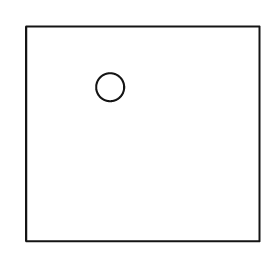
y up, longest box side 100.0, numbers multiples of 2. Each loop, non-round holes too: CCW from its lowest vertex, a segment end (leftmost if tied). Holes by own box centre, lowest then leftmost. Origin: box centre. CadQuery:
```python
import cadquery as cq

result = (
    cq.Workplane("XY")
    .moveTo(-50.0, -46.0)
    .lineTo(50.0, -46.0)
    .lineTo(50.0, 46.0)
    .lineTo(-50.0, 46.0)
    .close()
    .moveTo(-14.0, 20.0)
    .circle(6.0)
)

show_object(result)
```